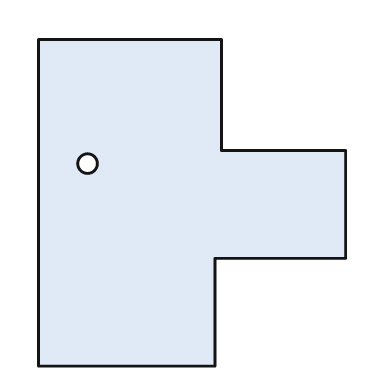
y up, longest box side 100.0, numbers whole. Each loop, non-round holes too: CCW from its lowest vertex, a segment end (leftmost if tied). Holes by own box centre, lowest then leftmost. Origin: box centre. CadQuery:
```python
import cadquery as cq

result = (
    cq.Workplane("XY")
    .moveTo(-47.0, -50.0)
    .lineTo(7.0, -50.0)
    .lineTo(7.0, -17.0)
    .lineTo(47.0, -17.0)
    .lineTo(47.0, 16.0)
    .lineTo(9.0, 16.0)
    .lineTo(9.0, 50.0)
    .lineTo(-47.0, 50.0)
    .close()
    .moveTo(-32.0, 12.0)
    .circle(3.0)
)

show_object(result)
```